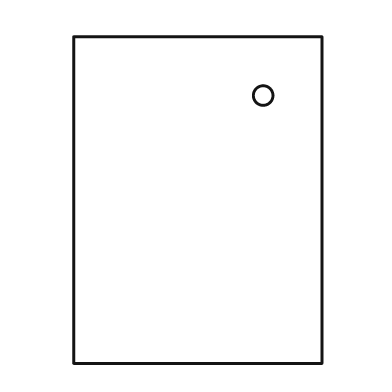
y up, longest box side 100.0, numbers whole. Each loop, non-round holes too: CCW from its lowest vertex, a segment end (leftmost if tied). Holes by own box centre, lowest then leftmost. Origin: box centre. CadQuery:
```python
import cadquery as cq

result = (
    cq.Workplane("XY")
    .moveTo(-38.0, -50.0)
    .lineTo(38.0, -50.0)
    .lineTo(38.0, 50.0)
    .lineTo(-38.0, 50.0)
    .close()
    .moveTo(20.0, 32.0)
    .circle(3.0)
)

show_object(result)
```